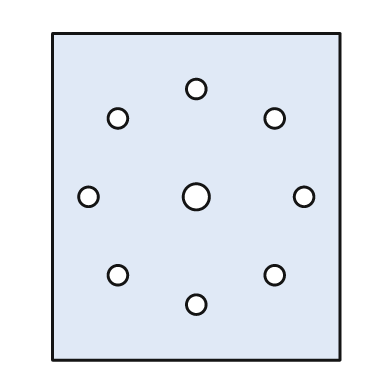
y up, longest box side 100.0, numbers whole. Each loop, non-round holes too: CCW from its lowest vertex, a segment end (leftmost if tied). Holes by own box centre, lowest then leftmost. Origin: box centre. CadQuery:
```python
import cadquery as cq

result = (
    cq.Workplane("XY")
    .moveTo(-44.0, -50.0)
    .lineTo(44.0, -50.0)
    .lineTo(44.0, 50.0)
    .lineTo(-44.0, 50.0)
    .close()
    .moveTo(0.0, -33.0)
    .circle(3.0)
    .moveTo(-24.0, -24.0)
    .circle(3.0)
    .moveTo(24.0, -24.0)
    .circle(3.0)
    .moveTo(-33.0, 0.0)
    .circle(3.0)
    .moveTo(0.0, 0.0)
    .circle(4.0)
    .moveTo(33.0, 0.0)
    .circle(3.0)
    .moveTo(-24.0, 24.0)
    .circle(3.0)
    .moveTo(24.0, 24.0)
    .circle(3.0)
    .moveTo(0.0, 33.0)
    .circle(3.0)
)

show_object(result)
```